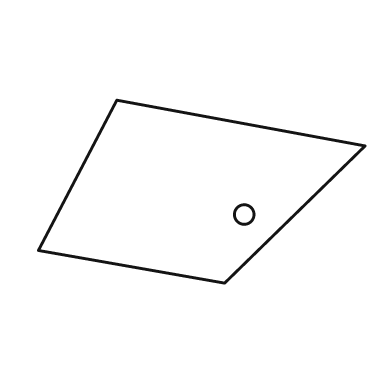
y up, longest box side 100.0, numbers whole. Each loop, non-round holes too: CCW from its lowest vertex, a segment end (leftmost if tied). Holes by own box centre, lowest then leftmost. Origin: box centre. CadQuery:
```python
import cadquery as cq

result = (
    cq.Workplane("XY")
    .moveTo(7.0, -28.0)
    .lineTo(50.0, 14.0)
    .lineTo(-26.0, 28.0)
    .lineTo(-50.0, -18.0)
    .close()
    .moveTo(13.0, -7.0)
    .circle(3.0)
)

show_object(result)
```